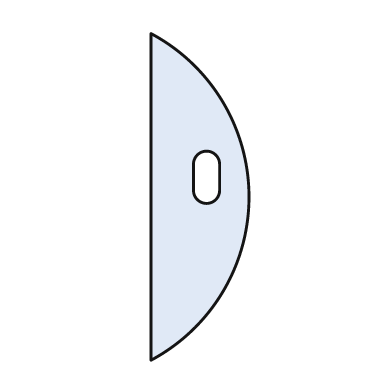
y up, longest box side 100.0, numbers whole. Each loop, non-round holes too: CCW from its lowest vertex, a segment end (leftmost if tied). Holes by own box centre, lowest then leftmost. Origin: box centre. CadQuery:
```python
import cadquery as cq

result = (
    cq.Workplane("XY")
    .moveTo(-15.0, -50.0)
    .threePointArc((15.0, 0.0), (-15.0, 50.0))
    .close()
    .moveTo(-2.0, 2.0)
    .threePointArc((2.0, -2.0), (6.0, 2.0))
    .lineTo(6.0, 10.0)
    .threePointArc((2.0, 14.0), (-2.0, 10.0))
    .close()
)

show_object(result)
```